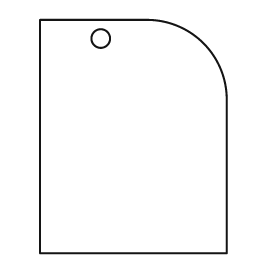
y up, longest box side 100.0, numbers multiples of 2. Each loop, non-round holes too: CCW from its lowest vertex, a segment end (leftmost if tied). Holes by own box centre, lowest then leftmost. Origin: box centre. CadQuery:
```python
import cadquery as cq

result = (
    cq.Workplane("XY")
    .moveTo(-40.0, -50.0)
    .lineTo(40.0, -50.0)
    .lineTo(40.0, 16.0)
    .threePointArc((30.0, 40.0), (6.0, 50.0))
    .lineTo(-40.0, 50.0)
    .close()
    .moveTo(-14.0, 42.0)
    .circle(4.0)
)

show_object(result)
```